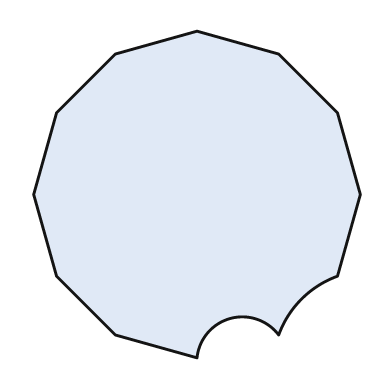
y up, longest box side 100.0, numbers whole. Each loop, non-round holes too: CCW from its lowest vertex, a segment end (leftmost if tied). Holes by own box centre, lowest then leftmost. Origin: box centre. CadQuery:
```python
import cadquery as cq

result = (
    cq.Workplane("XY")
    .moveTo(0.0, -50.0)
    .threePointArc((10.0, -38.0), (25.0, -43.0))
    .threePointArc((32.0, -32.0), (43.0, -25.0))
    .lineTo(50.0, 0.0)
    .lineTo(43.0, 25.0)
    .lineTo(25.0, 43.0)
    .lineTo(0.0, 50.0)
    .lineTo(-25.0, 43.0)
    .lineTo(-43.0, 25.0)
    .lineTo(-50.0, 0.0)
    .lineTo(-43.0, -25.0)
    .lineTo(-25.0, -43.0)
    .close()
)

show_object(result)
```